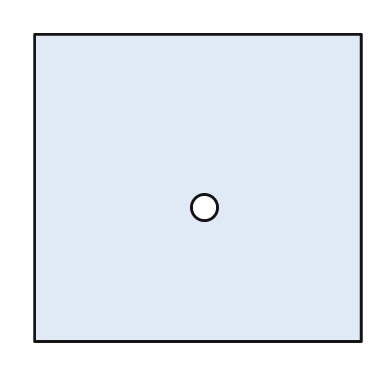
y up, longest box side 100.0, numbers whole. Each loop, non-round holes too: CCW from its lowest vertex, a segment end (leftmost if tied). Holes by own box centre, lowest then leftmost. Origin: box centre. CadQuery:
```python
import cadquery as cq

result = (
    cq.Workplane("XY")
    .moveTo(-50.0, -47.0)
    .lineTo(50.0, -47.0)
    .lineTo(50.0, 47.0)
    .lineTo(-50.0, 47.0)
    .close()
    .moveTo(2.0, -6.0)
    .circle(4.0)
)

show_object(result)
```